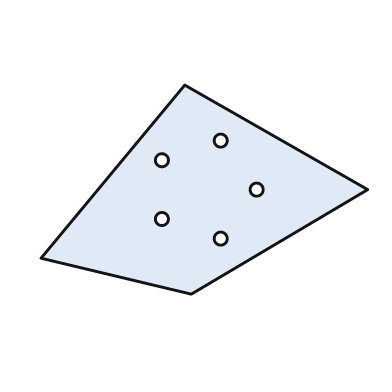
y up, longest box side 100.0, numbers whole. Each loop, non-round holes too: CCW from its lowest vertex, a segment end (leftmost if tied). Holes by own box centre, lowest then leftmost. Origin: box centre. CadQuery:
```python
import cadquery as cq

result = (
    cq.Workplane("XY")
    .moveTo(-4.0, -32.0)
    .lineTo(50.0, 0.0)
    .lineTo(-6.0, 32.0)
    .lineTo(-50.0, -21.0)
    .close()
    .moveTo(5.0, -15.0)
    .circle(2.0)
    .moveTo(-13.0, -9.0)
    .circle(2.0)
    .moveTo(16.0, 0.0)
    .circle(2.0)
    .moveTo(-13.0, 9.0)
    .circle(2.0)
    .moveTo(5.0, 15.0)
    .circle(2.0)
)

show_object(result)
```